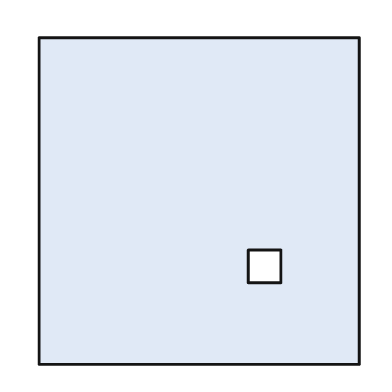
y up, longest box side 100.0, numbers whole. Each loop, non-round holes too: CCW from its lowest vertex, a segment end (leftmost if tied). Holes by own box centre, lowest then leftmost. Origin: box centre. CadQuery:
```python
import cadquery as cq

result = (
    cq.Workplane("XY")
    .moveTo(-49.0, -50.0)
    .lineTo(49.0, -50.0)
    .lineTo(49.0, 50.0)
    .lineTo(-49.0, 50.0)
    .close()
    .moveTo(15.0, -25.0)
    .lineTo(25.0, -25.0)
    .lineTo(25.0, -15.0)
    .lineTo(15.0, -15.0)
    .close()
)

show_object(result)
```